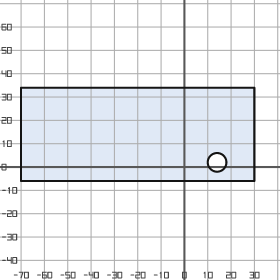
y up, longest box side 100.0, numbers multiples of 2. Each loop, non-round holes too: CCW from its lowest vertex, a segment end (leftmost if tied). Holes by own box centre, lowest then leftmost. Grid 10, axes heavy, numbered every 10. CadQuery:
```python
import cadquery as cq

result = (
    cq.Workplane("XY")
    .moveTo(-70.0, -6.0)
    .lineTo(30.0, -6.0)
    .lineTo(30.0, 34.0)
    .lineTo(-70.0, 34.0)
    .close()
    .moveTo(14.0, 2.0)
    .circle(4.0)
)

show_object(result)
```